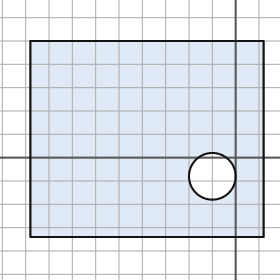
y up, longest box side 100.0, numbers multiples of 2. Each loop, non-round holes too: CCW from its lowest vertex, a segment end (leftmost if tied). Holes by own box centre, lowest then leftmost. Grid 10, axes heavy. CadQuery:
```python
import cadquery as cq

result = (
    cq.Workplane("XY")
    .moveTo(-88.0, -34.0)
    .lineTo(12.0, -34.0)
    .lineTo(12.0, 50.0)
    .lineTo(-88.0, 50.0)
    .close()
    .moveTo(-10.0, -8.0)
    .circle(10.0)
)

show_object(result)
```